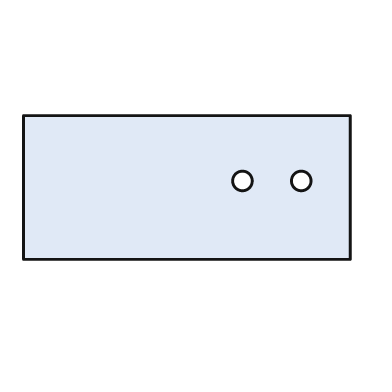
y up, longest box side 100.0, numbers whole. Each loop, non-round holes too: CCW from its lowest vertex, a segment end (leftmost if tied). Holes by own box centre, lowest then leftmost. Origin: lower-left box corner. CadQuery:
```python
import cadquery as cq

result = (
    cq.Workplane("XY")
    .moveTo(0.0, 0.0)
    .lineTo(100.0, 0.0)
    .lineTo(100.0, 44.0)
    .lineTo(0.0, 44.0)
    .close()
    .moveTo(67.0, 24.0)
    .circle(3.0)
    .moveTo(85.0, 24.0)
    .circle(3.0)
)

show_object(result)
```